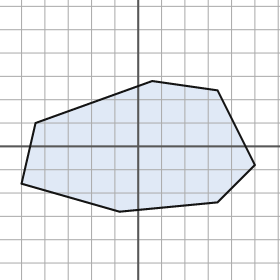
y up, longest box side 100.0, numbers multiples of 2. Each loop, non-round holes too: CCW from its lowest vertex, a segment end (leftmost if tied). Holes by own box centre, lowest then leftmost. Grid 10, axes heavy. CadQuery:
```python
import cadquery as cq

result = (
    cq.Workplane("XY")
    .moveTo(-8.0, -28.0)
    .lineTo(34.0, -24.0)
    .lineTo(50.0, -8.0)
    .lineTo(34.0, 24.0)
    .lineTo(6.0, 28.0)
    .lineTo(-44.0, 10.0)
    .lineTo(-50.0, -16.0)
    .close()
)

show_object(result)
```